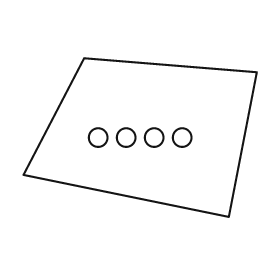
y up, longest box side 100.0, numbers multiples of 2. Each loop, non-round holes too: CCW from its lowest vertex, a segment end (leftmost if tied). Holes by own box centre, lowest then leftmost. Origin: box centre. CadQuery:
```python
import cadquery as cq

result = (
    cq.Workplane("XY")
    .moveTo(38.0, -34.0)
    .lineTo(50.0, 28.0)
    .lineTo(-24.0, 34.0)
    .lineTo(-50.0, -16.0)
    .close()
    .moveTo(-18.0, 0.0)
    .circle(4.0)
    .moveTo(-6.0, 0.0)
    .circle(4.0)
    .moveTo(6.0, 0.0)
    .circle(4.0)
    .moveTo(18.0, 0.0)
    .circle(4.0)
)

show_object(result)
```